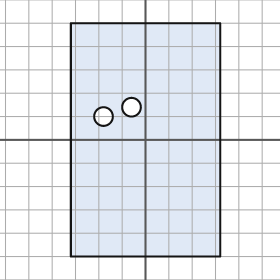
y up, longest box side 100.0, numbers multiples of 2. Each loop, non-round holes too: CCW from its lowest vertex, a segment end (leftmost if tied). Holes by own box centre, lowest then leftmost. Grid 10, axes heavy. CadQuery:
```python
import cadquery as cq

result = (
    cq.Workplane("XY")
    .moveTo(-32.0, -50.0)
    .lineTo(32.0, -50.0)
    .lineTo(32.0, 50.0)
    .lineTo(-32.0, 50.0)
    .close()
    .moveTo(-18.0, 10.0)
    .circle(4.0)
    .moveTo(-6.0, 14.0)
    .circle(4.0)
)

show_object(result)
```